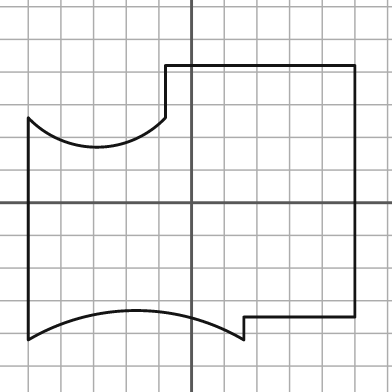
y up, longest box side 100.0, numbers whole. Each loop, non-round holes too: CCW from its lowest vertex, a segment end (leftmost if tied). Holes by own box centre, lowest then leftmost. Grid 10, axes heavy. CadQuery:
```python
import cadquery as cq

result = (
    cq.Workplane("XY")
    .moveTo(-50.0, -42.0)
    .threePointArc((-17.0, -33.0), (16.0, -42.0))
    .lineTo(16.0, -35.0)
    .lineTo(50.0, -35.0)
    .lineTo(50.0, 42.0)
    .lineTo(-8.0, 42.0)
    .lineTo(-8.0, 26.0)
    .threePointArc((-29.0, 17.0), (-50.0, 26.0))
    .close()
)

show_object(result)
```